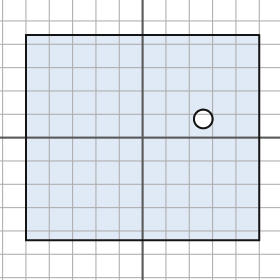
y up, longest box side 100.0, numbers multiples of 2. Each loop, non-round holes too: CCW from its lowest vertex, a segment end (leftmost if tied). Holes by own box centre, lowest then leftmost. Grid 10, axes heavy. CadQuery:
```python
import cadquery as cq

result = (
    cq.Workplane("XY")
    .moveTo(-50.0, -44.0)
    .lineTo(50.0, -44.0)
    .lineTo(50.0, 44.0)
    .lineTo(-50.0, 44.0)
    .close()
    .moveTo(26.0, 8.0)
    .circle(4.0)
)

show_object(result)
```